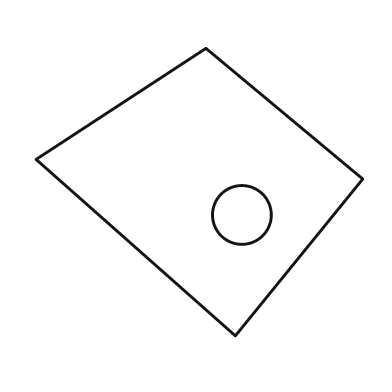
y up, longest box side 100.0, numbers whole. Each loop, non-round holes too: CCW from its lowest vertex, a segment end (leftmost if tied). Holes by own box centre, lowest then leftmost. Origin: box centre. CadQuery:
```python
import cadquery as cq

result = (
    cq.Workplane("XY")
    .moveTo(11.0, -44.0)
    .lineTo(50.0, 4.0)
    .lineTo(2.0, 44.0)
    .lineTo(-50.0, 10.0)
    .close()
    .moveTo(13.0, -7.0)
    .circle(9.0)
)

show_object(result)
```